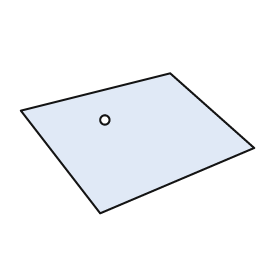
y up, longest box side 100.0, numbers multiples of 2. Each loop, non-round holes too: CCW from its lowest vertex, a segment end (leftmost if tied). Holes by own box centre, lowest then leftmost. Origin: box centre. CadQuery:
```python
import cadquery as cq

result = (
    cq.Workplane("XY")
    .moveTo(-16.0, -30.0)
    .lineTo(50.0, -2.0)
    .lineTo(14.0, 30.0)
    .lineTo(-50.0, 14.0)
    .close()
    .moveTo(-14.0, 10.0)
    .circle(2.0)
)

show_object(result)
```